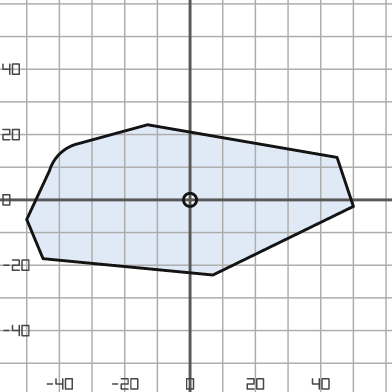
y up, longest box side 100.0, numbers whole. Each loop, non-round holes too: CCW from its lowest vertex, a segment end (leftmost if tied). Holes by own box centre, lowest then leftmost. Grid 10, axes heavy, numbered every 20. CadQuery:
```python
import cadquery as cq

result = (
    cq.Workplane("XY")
    .moveTo(7.0, -23.0)
    .lineTo(50.0, -2.0)
    .lineTo(45.0, 13.0)
    .lineTo(-13.0, 23.0)
    .lineTo(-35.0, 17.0)
    .threePointArc((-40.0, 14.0), (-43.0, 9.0))
    .lineTo(-50.0, -6.0)
    .lineTo(-45.0, -18.0)
    .close()
    .moveTo(0.0, 0.0)
    .circle(2.0)
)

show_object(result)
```